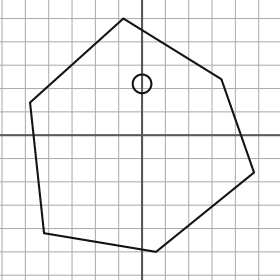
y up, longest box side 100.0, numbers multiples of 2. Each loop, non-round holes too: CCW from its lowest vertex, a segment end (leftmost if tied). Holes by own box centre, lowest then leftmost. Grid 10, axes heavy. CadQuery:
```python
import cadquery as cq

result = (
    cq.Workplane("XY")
    .moveTo(6.0, -50.0)
    .lineTo(48.0, -16.0)
    .lineTo(34.0, 24.0)
    .lineTo(-8.0, 50.0)
    .lineTo(-48.0, 14.0)
    .lineTo(-42.0, -42.0)
    .close()
    .moveTo(0.0, 22.0)
    .circle(4.0)
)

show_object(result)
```